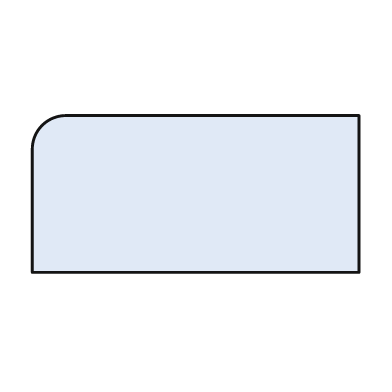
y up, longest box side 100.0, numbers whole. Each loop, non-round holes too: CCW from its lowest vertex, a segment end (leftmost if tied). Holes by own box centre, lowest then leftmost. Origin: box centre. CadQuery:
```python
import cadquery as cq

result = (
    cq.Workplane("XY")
    .moveTo(-50.0, -24.0)
    .lineTo(50.0, -24.0)
    .lineTo(50.0, 24.0)
    .lineTo(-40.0, 24.0)
    .threePointArc((-47.0, 21.0), (-50.0, 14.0))
    .close()
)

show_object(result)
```